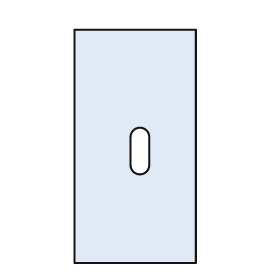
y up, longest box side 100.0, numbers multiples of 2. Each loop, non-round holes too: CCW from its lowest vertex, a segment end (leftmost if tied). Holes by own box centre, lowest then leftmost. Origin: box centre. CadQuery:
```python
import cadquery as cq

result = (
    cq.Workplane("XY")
    .moveTo(-26.0, -50.0)
    .lineTo(26.0, -50.0)
    .lineTo(26.0, 50.0)
    .lineTo(-26.0, 50.0)
    .close()
    .moveTo(-2.0, -8.0)
    .threePointArc((2.0, -12.0), (6.0, -8.0))
    .lineTo(6.0, 4.0)
    .threePointArc((2.0, 8.0), (-2.0, 4.0))
    .close()
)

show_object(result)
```